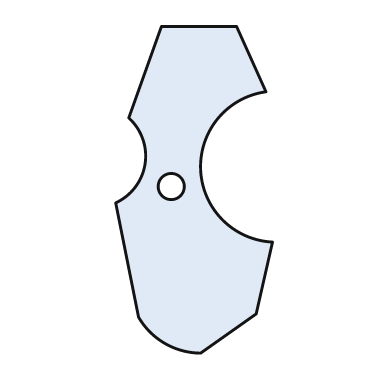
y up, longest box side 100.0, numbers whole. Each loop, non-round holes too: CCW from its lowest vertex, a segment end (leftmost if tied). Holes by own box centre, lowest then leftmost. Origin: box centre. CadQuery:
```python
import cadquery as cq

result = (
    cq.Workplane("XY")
    .moveTo(2.0, -50.0)
    .lineTo(19.0, -38.0)
    .lineTo(24.0, -16.0)
    .threePointArc((2.0, 6.0), (22.0, 30.0))
    .lineTo(13.0, 50.0)
    .lineTo(-10.0, 50.0)
    .lineTo(-20.0, 22.0)
    .threePointArc((-15.0, 8.0), (-24.0, -4.0))
    .lineTo(-17.0, -39.0)
    .threePointArc((-9.0, -47.0), (2.0, -50.0))
    .close()
    .moveTo(-7.0, 1.0)
    .circle(4.0)
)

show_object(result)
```